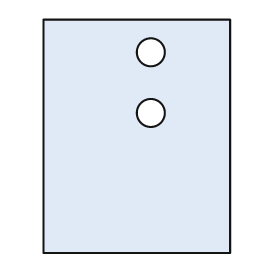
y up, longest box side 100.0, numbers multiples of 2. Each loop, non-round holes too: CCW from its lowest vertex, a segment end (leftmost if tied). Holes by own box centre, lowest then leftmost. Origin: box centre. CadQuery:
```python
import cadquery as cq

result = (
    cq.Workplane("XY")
    .moveTo(-40.0, -50.0)
    .lineTo(40.0, -50.0)
    .lineTo(40.0, 50.0)
    .lineTo(-40.0, 50.0)
    .close()
    .moveTo(6.0, 10.0)
    .circle(6.0)
    .moveTo(6.0, 36.0)
    .circle(6.0)
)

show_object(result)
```